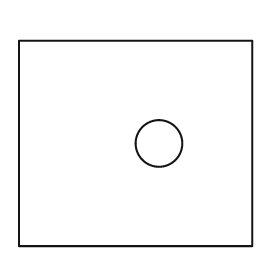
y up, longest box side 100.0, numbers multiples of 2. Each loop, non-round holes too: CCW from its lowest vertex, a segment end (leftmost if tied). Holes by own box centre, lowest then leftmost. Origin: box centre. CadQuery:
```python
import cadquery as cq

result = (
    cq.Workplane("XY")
    .moveTo(-50.0, -44.0)
    .lineTo(50.0, -44.0)
    .lineTo(50.0, 44.0)
    .lineTo(-50.0, 44.0)
    .close()
    .moveTo(10.0, 0.0)
    .circle(10.0)
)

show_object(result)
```